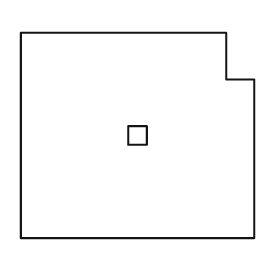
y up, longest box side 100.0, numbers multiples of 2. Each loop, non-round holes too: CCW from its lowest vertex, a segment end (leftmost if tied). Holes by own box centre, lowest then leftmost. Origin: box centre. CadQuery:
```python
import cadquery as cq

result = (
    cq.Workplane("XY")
    .moveTo(-50.0, -44.0)
    .lineTo(50.0, -44.0)
    .lineTo(50.0, 24.0)
    .lineTo(38.0, 24.0)
    .lineTo(38.0, 44.0)
    .lineTo(-50.0, 44.0)
    .close()
    .moveTo(-4.0, -4.0)
    .lineTo(4.0, -4.0)
    .lineTo(4.0, 4.0)
    .lineTo(-4.0, 4.0)
    .close()
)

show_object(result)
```